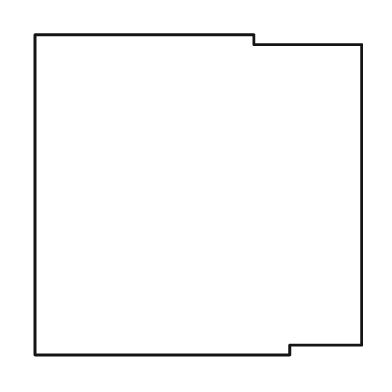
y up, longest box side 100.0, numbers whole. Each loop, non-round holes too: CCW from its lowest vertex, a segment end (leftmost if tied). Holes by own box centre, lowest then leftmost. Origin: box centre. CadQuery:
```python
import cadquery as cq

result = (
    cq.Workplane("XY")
    .moveTo(-50.0, -49.0)
    .lineTo(28.0, -49.0)
    .lineTo(28.0, -46.0)
    .lineTo(50.0, -46.0)
    .lineTo(50.0, 46.0)
    .lineTo(17.0, 46.0)
    .lineTo(17.0, 49.0)
    .lineTo(-50.0, 49.0)
    .close()
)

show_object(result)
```